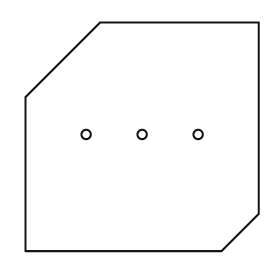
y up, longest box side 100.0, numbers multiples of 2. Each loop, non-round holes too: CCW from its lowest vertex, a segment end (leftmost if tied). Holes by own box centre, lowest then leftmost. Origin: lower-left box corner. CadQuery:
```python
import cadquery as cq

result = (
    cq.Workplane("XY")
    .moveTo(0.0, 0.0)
    .lineTo(84.0, 0.0)
    .lineTo(100.0, 16.0)
    .lineTo(100.0, 98.0)
    .lineTo(32.0, 98.0)
    .lineTo(0.0, 66.0)
    .close()
    .moveTo(26.0, 50.0)
    .circle(2.0)
    .moveTo(50.0, 50.0)
    .circle(2.0)
    .moveTo(74.0, 50.0)
    .circle(2.0)
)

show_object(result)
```